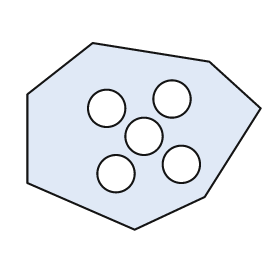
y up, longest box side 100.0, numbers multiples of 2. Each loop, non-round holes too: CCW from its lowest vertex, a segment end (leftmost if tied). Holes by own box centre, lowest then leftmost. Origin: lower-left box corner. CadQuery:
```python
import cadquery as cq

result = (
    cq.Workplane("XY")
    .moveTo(46.0, 0.0)
    .lineTo(76.0, 14.0)
    .lineTo(100.0, 52.0)
    .lineTo(78.0, 72.0)
    .lineTo(28.0, 80.0)
    .lineTo(0.0, 58.0)
    .lineTo(0.0, 20.0)
    .close()
    .moveTo(38.0, 24.0)
    .circle(8.0)
    .moveTo(66.0, 28.0)
    .circle(8.0)
    .moveTo(50.0, 40.0)
    .circle(8.0)
    .moveTo(34.0, 52.0)
    .circle(8.0)
    .moveTo(62.0, 56.0)
    .circle(8.0)
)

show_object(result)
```